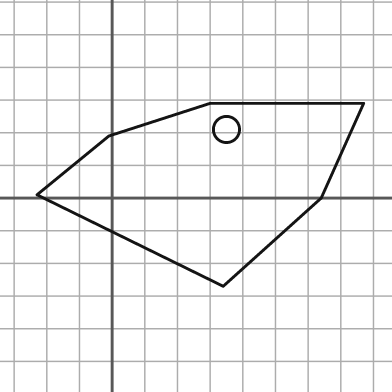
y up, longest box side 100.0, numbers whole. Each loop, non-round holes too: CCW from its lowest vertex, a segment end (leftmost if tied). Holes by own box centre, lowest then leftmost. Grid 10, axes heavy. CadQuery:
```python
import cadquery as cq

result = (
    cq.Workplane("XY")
    .moveTo(34.0, -27.0)
    .lineTo(64.0, 0.0)
    .lineTo(77.0, 29.0)
    .lineTo(30.0, 29.0)
    .lineTo(-1.0, 19.0)
    .lineTo(-23.0, 1.0)
    .close()
    .moveTo(35.0, 21.0)
    .circle(4.0)
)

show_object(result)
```